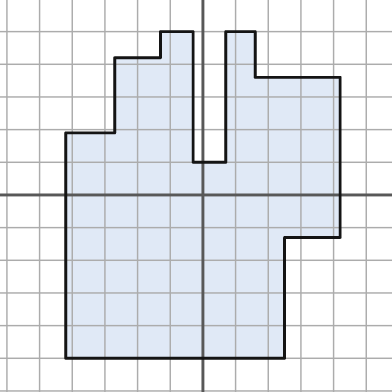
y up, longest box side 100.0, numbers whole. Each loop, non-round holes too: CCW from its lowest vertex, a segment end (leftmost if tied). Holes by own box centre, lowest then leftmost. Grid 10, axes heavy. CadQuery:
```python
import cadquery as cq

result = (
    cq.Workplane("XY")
    .moveTo(-42.0, -50.0)
    .lineTo(25.0, -50.0)
    .lineTo(25.0, -13.0)
    .lineTo(42.0, -13.0)
    .lineTo(42.0, 36.0)
    .lineTo(16.0, 36.0)
    .lineTo(16.0, 50.0)
    .lineTo(7.0, 50.0)
    .lineTo(7.0, 10.0)
    .lineTo(-3.0, 10.0)
    .lineTo(-3.0, 50.0)
    .lineTo(-13.0, 50.0)
    .lineTo(-13.0, 42.0)
    .lineTo(-27.0, 42.0)
    .lineTo(-27.0, 19.0)
    .lineTo(-42.0, 19.0)
    .close()
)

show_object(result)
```